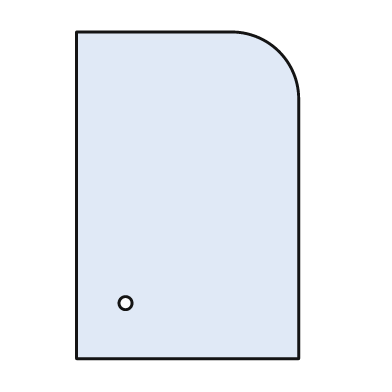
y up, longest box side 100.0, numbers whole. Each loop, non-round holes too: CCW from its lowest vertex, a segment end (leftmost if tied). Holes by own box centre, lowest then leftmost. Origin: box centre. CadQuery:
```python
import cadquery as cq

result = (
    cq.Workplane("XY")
    .moveTo(-34.0, -50.0)
    .lineTo(34.0, -50.0)
    .lineTo(34.0, 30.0)
    .threePointArc((28.0, 44.0), (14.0, 50.0))
    .lineTo(-34.0, 50.0)
    .close()
    .moveTo(-19.0, -33.0)
    .circle(2.0)
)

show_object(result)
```